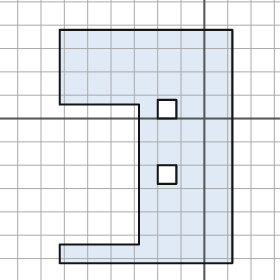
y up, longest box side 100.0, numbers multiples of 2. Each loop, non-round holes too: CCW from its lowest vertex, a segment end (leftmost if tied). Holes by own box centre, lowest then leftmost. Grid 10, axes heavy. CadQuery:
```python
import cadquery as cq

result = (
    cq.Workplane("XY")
    .moveTo(-62.0, -62.0)
    .lineTo(12.0, -62.0)
    .lineTo(12.0, 38.0)
    .lineTo(-62.0, 38.0)
    .lineTo(-62.0, 6.0)
    .lineTo(-28.0, 6.0)
    .lineTo(-28.0, -54.0)
    .lineTo(-62.0, -54.0)
    .close()
    .moveTo(-20.0, -28.0)
    .lineTo(-12.0, -28.0)
    .lineTo(-12.0, -20.0)
    .lineTo(-20.0, -20.0)
    .close()
    .moveTo(-20.0, 0.0)
    .lineTo(-12.0, 0.0)
    .lineTo(-12.0, 8.0)
    .lineTo(-20.0, 8.0)
    .close()
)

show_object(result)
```